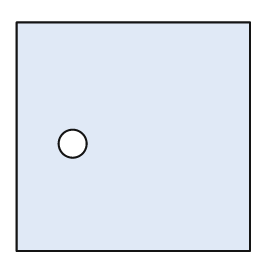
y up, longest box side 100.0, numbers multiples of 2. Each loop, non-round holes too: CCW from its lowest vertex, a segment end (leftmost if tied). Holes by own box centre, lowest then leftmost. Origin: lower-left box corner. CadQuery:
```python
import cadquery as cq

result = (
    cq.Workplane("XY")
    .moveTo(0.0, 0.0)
    .lineTo(100.0, 0.0)
    .lineTo(100.0, 98.0)
    .lineTo(0.0, 98.0)
    .close()
    .moveTo(24.0, 46.0)
    .circle(6.0)
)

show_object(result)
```